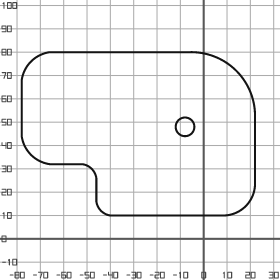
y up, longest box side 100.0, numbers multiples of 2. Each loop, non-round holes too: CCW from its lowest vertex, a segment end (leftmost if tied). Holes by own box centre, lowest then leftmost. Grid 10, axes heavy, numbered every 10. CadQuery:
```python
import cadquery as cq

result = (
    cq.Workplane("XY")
    .moveTo(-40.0, 10.0)
    .lineTo(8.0, 10.0)
    .threePointArc((18.0, 14.0), (22.0, 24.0))
    .lineTo(22.0, 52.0)
    .threePointArc((14.0, 72.0), (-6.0, 80.0))
    .lineTo(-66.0, 80.0)
    .threePointArc((-74.0, 76.0), (-78.0, 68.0))
    .lineTo(-78.0, 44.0)
    .threePointArc((-74.0, 36.0), (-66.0, 32.0))
    .lineTo(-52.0, 32.0)
    .threePointArc((-48.0, 30.0), (-46.0, 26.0))
    .lineTo(-46.0, 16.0)
    .threePointArc((-44.0, 12.0), (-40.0, 10.0))
    .close()
    .moveTo(-8.0, 48.0)
    .circle(4.0)
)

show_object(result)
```